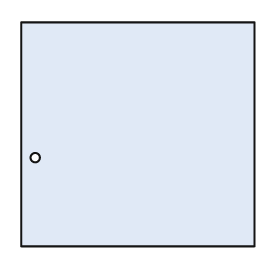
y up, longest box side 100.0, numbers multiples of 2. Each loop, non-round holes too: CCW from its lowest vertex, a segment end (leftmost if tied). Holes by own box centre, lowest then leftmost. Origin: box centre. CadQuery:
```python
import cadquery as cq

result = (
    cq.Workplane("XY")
    .moveTo(-50.0, -48.0)
    .lineTo(50.0, -48.0)
    .lineTo(50.0, 48.0)
    .lineTo(-50.0, 48.0)
    .close()
    .moveTo(-44.0, -10.0)
    .circle(2.0)
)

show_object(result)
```